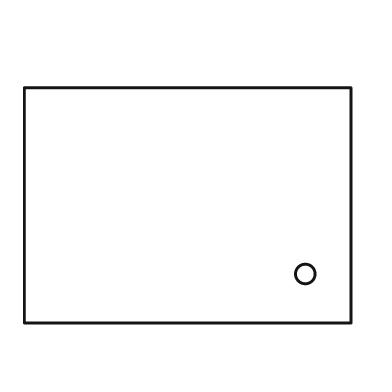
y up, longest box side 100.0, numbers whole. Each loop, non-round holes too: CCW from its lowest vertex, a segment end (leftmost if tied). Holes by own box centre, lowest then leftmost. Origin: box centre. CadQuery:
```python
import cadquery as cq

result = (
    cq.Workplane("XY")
    .moveTo(-50.0, -36.0)
    .lineTo(50.0, -36.0)
    .lineTo(50.0, 36.0)
    .lineTo(-50.0, 36.0)
    .close()
    .moveTo(36.0, -21.0)
    .circle(3.0)
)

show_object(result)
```